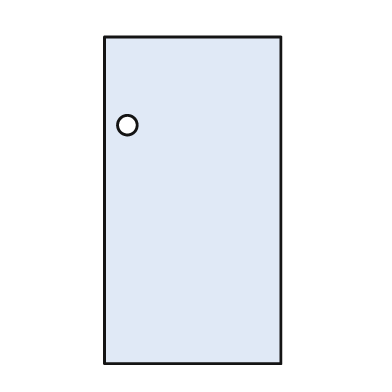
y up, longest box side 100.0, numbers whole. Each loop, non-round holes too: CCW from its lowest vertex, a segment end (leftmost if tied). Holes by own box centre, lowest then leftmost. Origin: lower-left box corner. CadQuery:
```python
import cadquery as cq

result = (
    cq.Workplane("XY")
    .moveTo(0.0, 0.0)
    .lineTo(54.0, 0.0)
    .lineTo(54.0, 100.0)
    .lineTo(0.0, 100.0)
    .close()
    .moveTo(7.0, 73.0)
    .circle(3.0)
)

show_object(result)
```